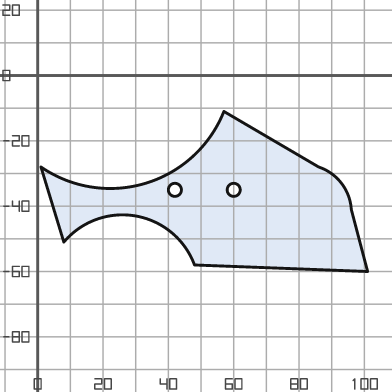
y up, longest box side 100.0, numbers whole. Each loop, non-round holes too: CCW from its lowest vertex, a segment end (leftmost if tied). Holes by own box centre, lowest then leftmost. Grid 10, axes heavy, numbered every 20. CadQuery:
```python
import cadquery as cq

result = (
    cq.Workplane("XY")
    .moveTo(101.0, -60.0)
    .lineTo(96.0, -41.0)
    .threePointArc((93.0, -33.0), (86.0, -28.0))
    .lineTo(57.0, -11.0)
    .threePointArc((33.0, -33.0), (1.0, -28.0))
    .lineTo(8.0, -51.0)
    .threePointArc((30.0, -43.0), (48.0, -58.0))
    .close()
    .moveTo(42.0, -35.0)
    .circle(2.0)
    .moveTo(60.0, -35.0)
    .circle(2.0)
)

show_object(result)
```